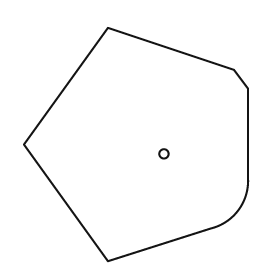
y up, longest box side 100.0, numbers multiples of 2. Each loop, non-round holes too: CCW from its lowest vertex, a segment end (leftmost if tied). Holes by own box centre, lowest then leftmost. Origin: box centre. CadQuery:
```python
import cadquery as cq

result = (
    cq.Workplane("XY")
    .moveTo(-12.0, -50.0)
    .lineTo(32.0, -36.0)
    .threePointArc((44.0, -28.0), (48.0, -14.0))
    .lineTo(48.0, 24.0)
    .lineTo(42.0, 32.0)
    .lineTo(-12.0, 50.0)
    .lineTo(-48.0, 0.0)
    .close()
    .moveTo(12.0, -4.0)
    .circle(2.0)
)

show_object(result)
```